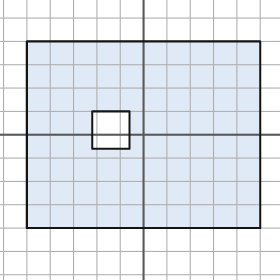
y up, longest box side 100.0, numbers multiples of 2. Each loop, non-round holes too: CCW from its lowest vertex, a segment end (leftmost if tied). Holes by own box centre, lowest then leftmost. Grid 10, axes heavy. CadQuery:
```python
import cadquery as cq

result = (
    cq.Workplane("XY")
    .moveTo(-50.0, -40.0)
    .lineTo(50.0, -40.0)
    .lineTo(50.0, 40.0)
    .lineTo(-50.0, 40.0)
    .close()
    .moveTo(-22.0, -6.0)
    .lineTo(-6.0, -6.0)
    .lineTo(-6.0, 10.0)
    .lineTo(-22.0, 10.0)
    .close()
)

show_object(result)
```